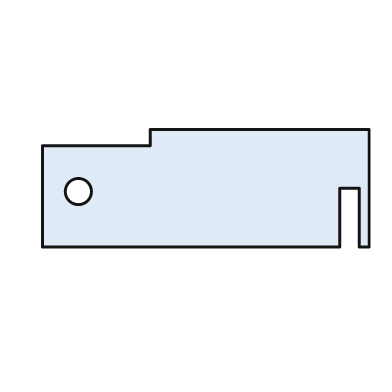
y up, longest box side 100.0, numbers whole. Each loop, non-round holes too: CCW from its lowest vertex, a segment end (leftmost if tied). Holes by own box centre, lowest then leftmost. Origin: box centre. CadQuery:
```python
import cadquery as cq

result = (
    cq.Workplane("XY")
    .moveTo(-50.0, -18.0)
    .lineTo(41.0, -18.0)
    .lineTo(41.0, 0.0)
    .lineTo(47.0, 0.0)
    .lineTo(47.0, -18.0)
    .lineTo(50.0, -18.0)
    .lineTo(50.0, 18.0)
    .lineTo(-17.0, 18.0)
    .lineTo(-17.0, 13.0)
    .lineTo(-50.0, 13.0)
    .close()
    .moveTo(-39.0, -1.0)
    .circle(4.0)
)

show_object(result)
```